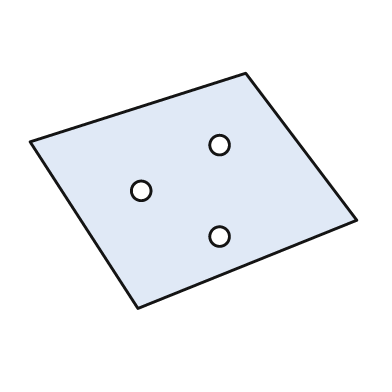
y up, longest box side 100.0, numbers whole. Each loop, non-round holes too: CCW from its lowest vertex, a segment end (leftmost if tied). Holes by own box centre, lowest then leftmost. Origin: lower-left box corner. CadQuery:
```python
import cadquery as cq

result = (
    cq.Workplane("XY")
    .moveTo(33.0, 0.0)
    .lineTo(100.0, 27.0)
    .lineTo(66.0, 72.0)
    .lineTo(0.0, 51.0)
    .close()
    .moveTo(58.0, 22.0)
    .circle(3.0)
    .moveTo(34.0, 36.0)
    .circle(3.0)
    .moveTo(58.0, 50.0)
    .circle(3.0)
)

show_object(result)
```